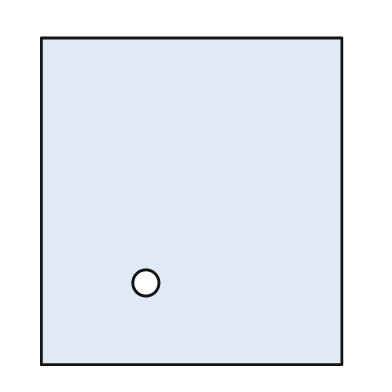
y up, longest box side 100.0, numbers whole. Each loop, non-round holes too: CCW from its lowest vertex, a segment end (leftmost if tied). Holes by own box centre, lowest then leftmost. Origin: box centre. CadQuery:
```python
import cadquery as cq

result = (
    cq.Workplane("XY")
    .moveTo(-46.0, -50.0)
    .lineTo(46.0, -50.0)
    .lineTo(46.0, 50.0)
    .lineTo(-46.0, 50.0)
    .close()
    .moveTo(-14.0, -25.0)
    .circle(4.0)
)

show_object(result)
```